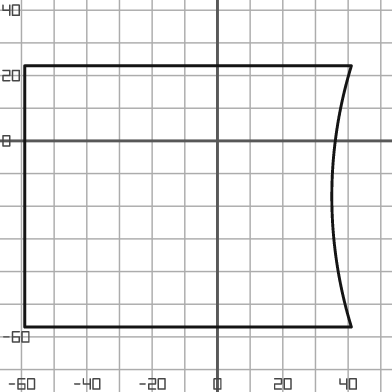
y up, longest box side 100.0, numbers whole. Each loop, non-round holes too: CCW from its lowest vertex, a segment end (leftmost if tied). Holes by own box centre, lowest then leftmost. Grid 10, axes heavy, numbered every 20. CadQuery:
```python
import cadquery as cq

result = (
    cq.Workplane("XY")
    .moveTo(-59.0, -57.0)
    .lineTo(41.0, -57.0)
    .threePointArc((35.0, -17.0), (41.0, 23.0))
    .lineTo(-59.0, 23.0)
    .close()
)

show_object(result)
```